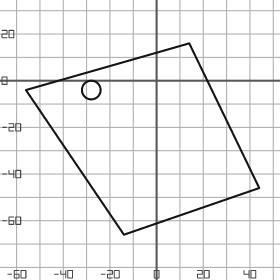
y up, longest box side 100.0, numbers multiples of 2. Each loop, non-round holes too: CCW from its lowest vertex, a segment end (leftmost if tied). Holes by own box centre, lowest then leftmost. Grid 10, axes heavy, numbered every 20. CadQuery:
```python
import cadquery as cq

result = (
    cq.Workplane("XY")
    .moveTo(-14.0, -66.0)
    .lineTo(44.0, -46.0)
    .lineTo(14.0, 16.0)
    .lineTo(-56.0, -4.0)
    .close()
    .moveTo(-28.0, -4.0)
    .circle(4.0)
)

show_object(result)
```